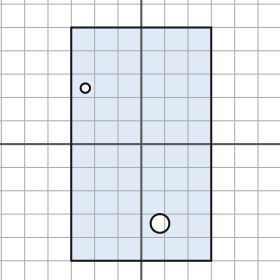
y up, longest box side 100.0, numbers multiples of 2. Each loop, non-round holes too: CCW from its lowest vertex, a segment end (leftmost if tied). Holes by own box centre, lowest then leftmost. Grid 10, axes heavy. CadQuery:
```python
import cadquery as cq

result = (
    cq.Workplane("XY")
    .moveTo(-30.0, -50.0)
    .lineTo(30.0, -50.0)
    .lineTo(30.0, 50.0)
    .lineTo(-30.0, 50.0)
    .close()
    .moveTo(8.0, -34.0)
    .circle(4.0)
    .moveTo(-24.0, 24.0)
    .circle(2.0)
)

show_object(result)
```